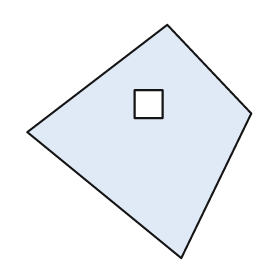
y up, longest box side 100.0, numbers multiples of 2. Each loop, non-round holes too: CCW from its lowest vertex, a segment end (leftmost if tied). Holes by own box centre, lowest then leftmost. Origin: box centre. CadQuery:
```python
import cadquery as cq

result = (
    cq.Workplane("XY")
    .moveTo(18.0, -50.0)
    .lineTo(48.0, 12.0)
    .lineTo(12.0, 50.0)
    .lineTo(-48.0, 4.0)
    .close()
    .moveTo(-2.0, 10.0)
    .lineTo(10.0, 10.0)
    .lineTo(10.0, 22.0)
    .lineTo(-2.0, 22.0)
    .close()
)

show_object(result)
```